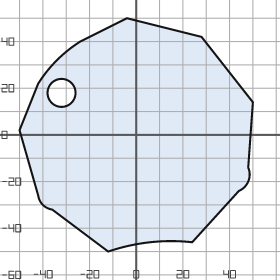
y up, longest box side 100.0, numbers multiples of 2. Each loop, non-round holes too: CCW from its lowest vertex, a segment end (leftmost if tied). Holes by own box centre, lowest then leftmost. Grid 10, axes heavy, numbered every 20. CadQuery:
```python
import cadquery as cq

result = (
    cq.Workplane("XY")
    .moveTo(-12.0, -50.0)
    .threePointArc((6.0, -46.0), (24.0, -46.0))
    .lineTo(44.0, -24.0)
    .threePointArc((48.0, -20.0), (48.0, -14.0))
    .lineTo(50.0, 14.0)
    .lineTo(28.0, 42.0)
    .lineTo(-4.0, 50.0)
    .lineTo(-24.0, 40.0)
    .threePointArc((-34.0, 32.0), (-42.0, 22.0))
    .lineTo(-50.0, 2.0)
    .lineTo(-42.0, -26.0)
    .threePointArc((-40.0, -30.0), (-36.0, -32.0))
    .close()
    .moveTo(-32.0, 18.0)
    .circle(6.0)
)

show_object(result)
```